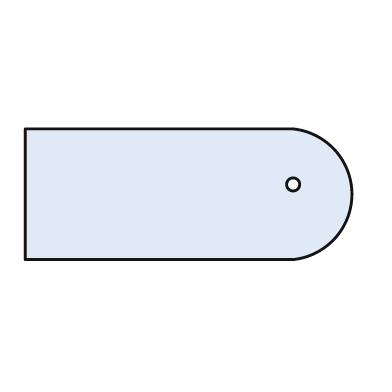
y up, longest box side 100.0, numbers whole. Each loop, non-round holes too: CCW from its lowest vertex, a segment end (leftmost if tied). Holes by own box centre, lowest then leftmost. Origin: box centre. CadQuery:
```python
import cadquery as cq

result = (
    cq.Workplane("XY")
    .moveTo(-50.0, -20.0)
    .lineTo(32.0, -20.0)
    .threePointArc((50.0, 0.0), (32.0, 20.0))
    .lineTo(-50.0, 20.0)
    .close()
    .moveTo(32.0, 3.0)
    .circle(2.0)
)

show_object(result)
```